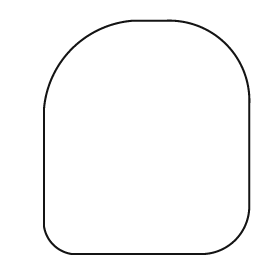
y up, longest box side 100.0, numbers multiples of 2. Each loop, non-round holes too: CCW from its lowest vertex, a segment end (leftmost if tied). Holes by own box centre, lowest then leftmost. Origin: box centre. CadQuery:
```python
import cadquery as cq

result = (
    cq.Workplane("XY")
    .moveTo(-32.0, -50.0)
    .lineTo(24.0, -50.0)
    .threePointArc((38.0, -44.0), (44.0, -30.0))
    .lineTo(44.0, 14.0)
    .threePointArc((34.0, 40.0), (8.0, 50.0))
    .lineTo(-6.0, 50.0)
    .threePointArc((-32.0, 38.0), (-44.0, 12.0))
    .lineTo(-44.0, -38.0)
    .threePointArc((-40.0, -46.0), (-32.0, -50.0))
    .close()
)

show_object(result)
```